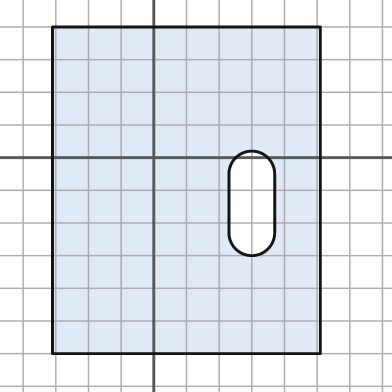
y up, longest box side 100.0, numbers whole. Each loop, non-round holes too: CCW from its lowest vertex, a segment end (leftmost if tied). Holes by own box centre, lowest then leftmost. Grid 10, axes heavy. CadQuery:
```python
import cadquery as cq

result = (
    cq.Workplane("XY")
    .moveTo(-31.0, -60.0)
    .lineTo(51.0, -60.0)
    .lineTo(51.0, 40.0)
    .lineTo(-31.0, 40.0)
    .close()
    .moveTo(23.0, -23.0)
    .threePointArc((30.0, -30.0), (37.0, -23.0))
    .lineTo(37.0, -5.0)
    .threePointArc((30.0, 2.0), (23.0, -5.0))
    .close()
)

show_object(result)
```